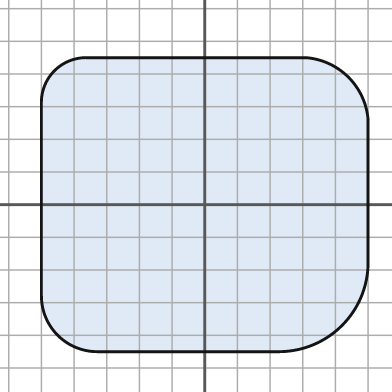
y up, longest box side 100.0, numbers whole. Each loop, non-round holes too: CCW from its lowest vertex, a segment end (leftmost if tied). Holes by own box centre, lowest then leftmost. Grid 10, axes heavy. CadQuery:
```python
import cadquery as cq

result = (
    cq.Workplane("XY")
    .moveTo(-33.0, -45.0)
    .lineTo(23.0, -45.0)
    .threePointArc((42.0, -37.0), (50.0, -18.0))
    .lineTo(50.0, 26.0)
    .threePointArc((44.0, 39.0), (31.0, 45.0))
    .lineTo(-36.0, 45.0)
    .threePointArc((-46.0, 41.0), (-50.0, 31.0))
    .lineTo(-50.0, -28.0)
    .threePointArc((-45.0, -40.0), (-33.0, -45.0))
    .close()
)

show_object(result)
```